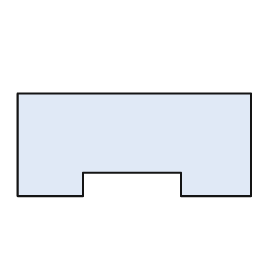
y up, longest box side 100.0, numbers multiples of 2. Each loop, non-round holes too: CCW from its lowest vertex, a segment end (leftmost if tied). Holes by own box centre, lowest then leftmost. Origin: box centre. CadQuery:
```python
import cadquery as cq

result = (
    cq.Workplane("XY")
    .moveTo(-50.0, -22.0)
    .lineTo(-22.0, -22.0)
    .lineTo(-22.0, -12.0)
    .lineTo(20.0, -12.0)
    .lineTo(20.0, -22.0)
    .lineTo(50.0, -22.0)
    .lineTo(50.0, 22.0)
    .lineTo(-50.0, 22.0)
    .close()
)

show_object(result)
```